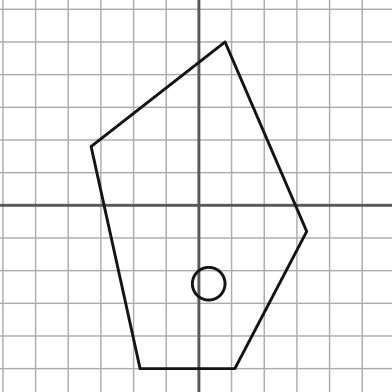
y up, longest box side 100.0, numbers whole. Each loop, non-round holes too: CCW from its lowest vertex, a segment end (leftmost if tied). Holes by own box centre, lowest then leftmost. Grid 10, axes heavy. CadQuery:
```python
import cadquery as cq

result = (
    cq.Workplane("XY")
    .moveTo(-18.0, -50.0)
    .lineTo(11.0, -50.0)
    .lineTo(33.0, -8.0)
    .lineTo(8.0, 50.0)
    .lineTo(-33.0, 18.0)
    .close()
    .moveTo(3.0, -24.0)
    .circle(5.0)
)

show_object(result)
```